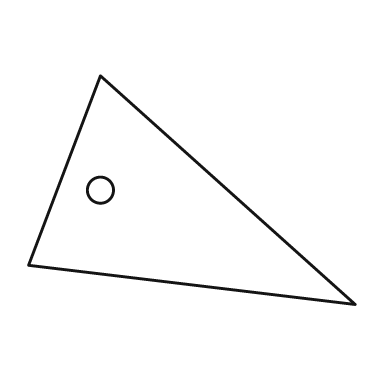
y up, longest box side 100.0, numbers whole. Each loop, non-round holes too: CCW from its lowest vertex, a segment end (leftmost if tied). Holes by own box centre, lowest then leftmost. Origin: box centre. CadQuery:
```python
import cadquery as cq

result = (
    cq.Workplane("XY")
    .moveTo(50.0, -35.0)
    .lineTo(-28.0, 35.0)
    .lineTo(-50.0, -23.0)
    .close()
    .moveTo(-28.0, 0.0)
    .circle(4.0)
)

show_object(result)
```